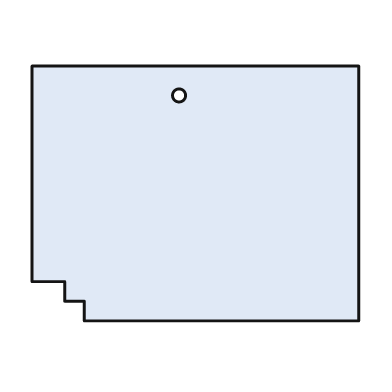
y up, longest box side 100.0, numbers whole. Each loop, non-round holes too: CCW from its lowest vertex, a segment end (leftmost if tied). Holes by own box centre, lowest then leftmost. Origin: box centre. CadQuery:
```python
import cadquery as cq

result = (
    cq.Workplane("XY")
    .moveTo(-34.0, -39.0)
    .lineTo(50.0, -39.0)
    .lineTo(50.0, 39.0)
    .lineTo(-50.0, 39.0)
    .lineTo(-50.0, -27.0)
    .lineTo(-40.0, -27.0)
    .lineTo(-40.0, -33.0)
    .lineTo(-34.0, -33.0)
    .close()
    .moveTo(-5.0, 30.0)
    .circle(2.0)
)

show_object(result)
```